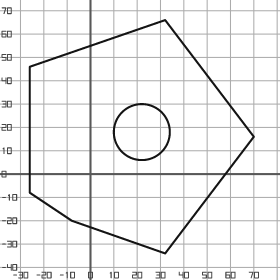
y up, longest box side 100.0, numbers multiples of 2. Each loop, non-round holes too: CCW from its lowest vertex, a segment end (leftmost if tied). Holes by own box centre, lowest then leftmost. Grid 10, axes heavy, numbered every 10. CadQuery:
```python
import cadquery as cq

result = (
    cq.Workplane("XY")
    .moveTo(32.0, -34.0)
    .lineTo(70.0, 16.0)
    .lineTo(32.0, 66.0)
    .lineTo(-26.0, 46.0)
    .lineTo(-26.0, -8.0)
    .lineTo(-8.0, -20.0)
    .close()
    .moveTo(22.0, 18.0)
    .circle(12.0)
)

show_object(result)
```